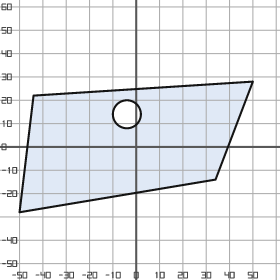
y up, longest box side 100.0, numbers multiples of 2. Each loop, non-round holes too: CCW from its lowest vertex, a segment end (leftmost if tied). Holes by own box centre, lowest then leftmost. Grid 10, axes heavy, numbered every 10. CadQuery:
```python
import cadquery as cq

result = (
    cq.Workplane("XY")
    .moveTo(-50.0, -28.0)
    .lineTo(34.0, -14.0)
    .lineTo(50.0, 28.0)
    .lineTo(-44.0, 22.0)
    .close()
    .moveTo(-4.0, 14.0)
    .circle(6.0)
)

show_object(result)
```